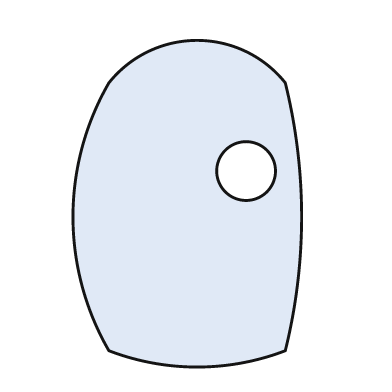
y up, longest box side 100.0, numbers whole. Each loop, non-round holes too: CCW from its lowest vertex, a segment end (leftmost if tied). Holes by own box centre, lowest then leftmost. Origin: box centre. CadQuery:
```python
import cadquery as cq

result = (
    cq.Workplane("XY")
    .moveTo(-24.0, -45.0)
    .threePointArc((3.0, -50.0), (30.0, -45.0))
    .threePointArc((35.0, -4.0), (30.0, 37.0))
    .threePointArc((3.0, 50.0), (-24.0, 37.0))
    .threePointArc((-35.0, -4.0), (-24.0, -45.0))
    .close()
    .moveTo(18.0, 10.0)
    .circle(9.0)
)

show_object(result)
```